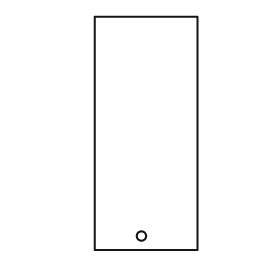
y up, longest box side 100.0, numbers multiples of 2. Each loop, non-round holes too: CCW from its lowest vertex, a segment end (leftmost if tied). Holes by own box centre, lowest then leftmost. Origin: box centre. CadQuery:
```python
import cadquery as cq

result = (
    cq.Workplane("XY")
    .moveTo(-22.0, -50.0)
    .lineTo(22.0, -50.0)
    .lineTo(22.0, 50.0)
    .lineTo(-22.0, 50.0)
    .close()
    .moveTo(-2.0, -44.0)
    .circle(2.0)
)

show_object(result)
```